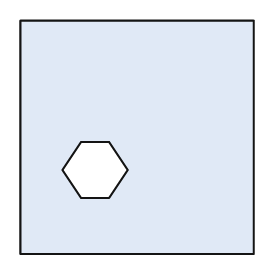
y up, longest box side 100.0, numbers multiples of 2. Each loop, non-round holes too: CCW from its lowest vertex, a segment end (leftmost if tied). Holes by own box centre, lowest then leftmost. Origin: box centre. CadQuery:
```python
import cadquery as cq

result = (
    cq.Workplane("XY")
    .moveTo(-50.0, -50.0)
    .lineTo(50.0, -50.0)
    .lineTo(50.0, 50.0)
    .lineTo(-50.0, 50.0)
    .close()
    .moveTo(-24.0, -26.0)
    .lineTo(-12.0, -26.0)
    .lineTo(-4.0, -14.0)
    .lineTo(-12.0, -2.0)
    .lineTo(-24.0, -2.0)
    .lineTo(-32.0, -14.0)
    .close()
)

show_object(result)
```